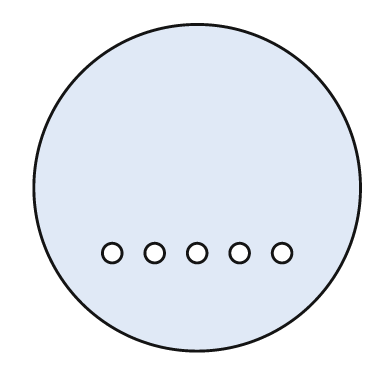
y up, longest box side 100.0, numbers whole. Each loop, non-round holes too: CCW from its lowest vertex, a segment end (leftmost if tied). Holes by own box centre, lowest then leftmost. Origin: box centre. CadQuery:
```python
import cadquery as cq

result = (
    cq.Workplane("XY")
    .moveTo(0.0, 0.0)
    .circle(50.0)
    .moveTo(-26.0, -20.0)
    .circle(3.0)
    .moveTo(-13.0, -20.0)
    .circle(3.0)
    .moveTo(0.0, -20.0)
    .circle(3.0)
    .moveTo(13.0, -20.0)
    .circle(3.0)
    .moveTo(26.0, -20.0)
    .circle(3.0)
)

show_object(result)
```